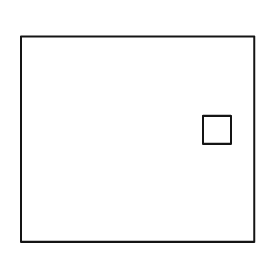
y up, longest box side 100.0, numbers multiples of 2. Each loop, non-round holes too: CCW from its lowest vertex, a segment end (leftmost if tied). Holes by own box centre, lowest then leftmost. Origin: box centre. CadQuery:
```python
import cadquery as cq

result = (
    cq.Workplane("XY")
    .moveTo(-50.0, -44.0)
    .lineTo(50.0, -44.0)
    .lineTo(50.0, 44.0)
    .lineTo(-50.0, 44.0)
    .close()
    .moveTo(28.0, -2.0)
    .lineTo(40.0, -2.0)
    .lineTo(40.0, 10.0)
    .lineTo(28.0, 10.0)
    .close()
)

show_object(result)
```